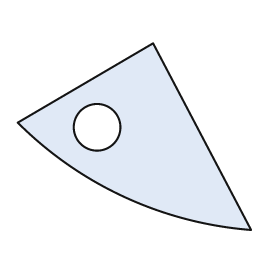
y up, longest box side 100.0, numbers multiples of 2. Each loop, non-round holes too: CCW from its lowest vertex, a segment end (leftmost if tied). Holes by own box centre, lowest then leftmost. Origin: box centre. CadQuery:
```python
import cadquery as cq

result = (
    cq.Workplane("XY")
    .moveTo(50.0, -40.0)
    .lineTo(8.0, 40.0)
    .lineTo(-50.0, 6.0)
    .threePointArc((-4.0, -26.0), (50.0, -40.0))
    .close()
    .moveTo(-16.0, 4.0)
    .circle(10.0)
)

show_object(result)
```